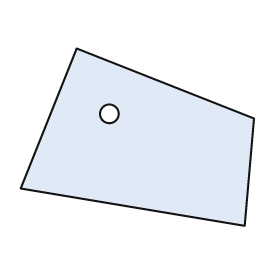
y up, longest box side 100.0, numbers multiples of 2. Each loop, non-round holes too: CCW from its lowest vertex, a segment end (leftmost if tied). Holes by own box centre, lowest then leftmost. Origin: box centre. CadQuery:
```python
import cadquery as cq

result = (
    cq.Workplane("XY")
    .moveTo(46.0, -38.0)
    .lineTo(50.0, 8.0)
    .lineTo(-26.0, 38.0)
    .lineTo(-50.0, -22.0)
    .close()
    .moveTo(-12.0, 10.0)
    .circle(4.0)
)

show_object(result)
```